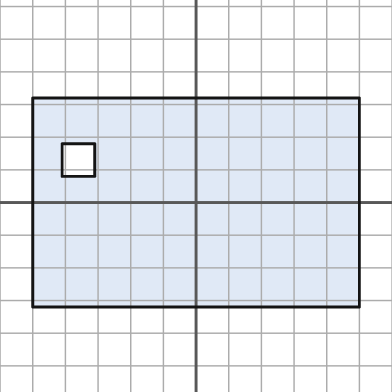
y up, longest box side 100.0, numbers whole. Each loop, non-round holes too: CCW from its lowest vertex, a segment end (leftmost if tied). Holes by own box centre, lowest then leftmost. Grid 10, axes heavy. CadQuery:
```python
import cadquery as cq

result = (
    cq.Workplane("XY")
    .moveTo(-50.0, -32.0)
    .lineTo(50.0, -32.0)
    .lineTo(50.0, 32.0)
    .lineTo(-50.0, 32.0)
    .close()
    .moveTo(-41.0, 8.0)
    .lineTo(-31.0, 8.0)
    .lineTo(-31.0, 18.0)
    .lineTo(-41.0, 18.0)
    .close()
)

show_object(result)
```